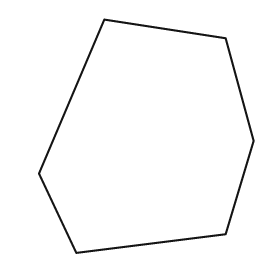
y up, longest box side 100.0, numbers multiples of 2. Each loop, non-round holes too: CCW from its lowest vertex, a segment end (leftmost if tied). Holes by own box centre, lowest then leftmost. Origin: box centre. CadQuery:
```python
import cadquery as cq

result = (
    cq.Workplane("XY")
    .moveTo(-30.0, -50.0)
    .lineTo(34.0, -42.0)
    .lineTo(46.0, -2.0)
    .lineTo(34.0, 42.0)
    .lineTo(-18.0, 50.0)
    .lineTo(-46.0, -16.0)
    .close()
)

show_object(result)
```